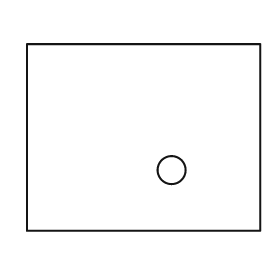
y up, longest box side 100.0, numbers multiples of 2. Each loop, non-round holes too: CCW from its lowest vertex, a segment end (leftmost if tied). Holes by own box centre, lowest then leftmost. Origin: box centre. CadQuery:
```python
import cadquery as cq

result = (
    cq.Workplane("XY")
    .moveTo(-50.0, -40.0)
    .lineTo(50.0, -40.0)
    .lineTo(50.0, 40.0)
    .lineTo(-50.0, 40.0)
    .close()
    .moveTo(12.0, -14.0)
    .circle(6.0)
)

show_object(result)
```